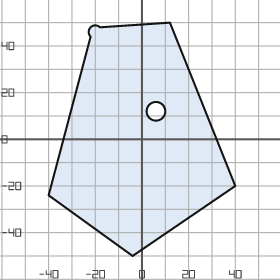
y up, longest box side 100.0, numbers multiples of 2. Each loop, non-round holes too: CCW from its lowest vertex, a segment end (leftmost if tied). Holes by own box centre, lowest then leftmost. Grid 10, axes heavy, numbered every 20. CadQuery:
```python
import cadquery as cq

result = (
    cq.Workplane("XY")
    .moveTo(-4.0, -50.0)
    .lineTo(40.0, -20.0)
    .lineTo(12.0, 50.0)
    .lineTo(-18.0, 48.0)
    .threePointArc((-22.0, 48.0), (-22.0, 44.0))
    .lineTo(-40.0, -24.0)
    .close()
    .moveTo(6.0, 12.0)
    .circle(4.0)
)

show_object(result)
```